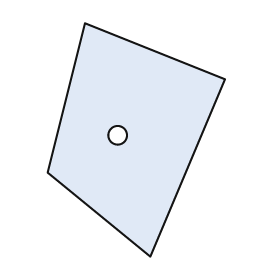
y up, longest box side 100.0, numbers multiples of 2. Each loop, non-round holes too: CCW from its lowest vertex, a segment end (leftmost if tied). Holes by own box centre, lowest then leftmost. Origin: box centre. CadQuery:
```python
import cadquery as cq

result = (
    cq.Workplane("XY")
    .moveTo(6.0, -50.0)
    .lineTo(38.0, 26.0)
    .lineTo(-22.0, 50.0)
    .lineTo(-38.0, -14.0)
    .close()
    .moveTo(-8.0, 2.0)
    .circle(4.0)
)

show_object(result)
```